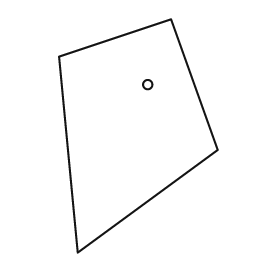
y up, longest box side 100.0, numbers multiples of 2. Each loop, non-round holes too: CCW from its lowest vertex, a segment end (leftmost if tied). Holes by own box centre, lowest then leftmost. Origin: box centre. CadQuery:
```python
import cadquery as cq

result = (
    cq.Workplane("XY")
    .moveTo(-26.0, -50.0)
    .lineTo(34.0, -6.0)
    .lineTo(14.0, 50.0)
    .lineTo(-34.0, 34.0)
    .close()
    .moveTo(4.0, 22.0)
    .circle(2.0)
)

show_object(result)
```